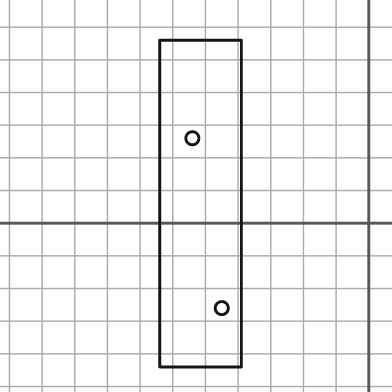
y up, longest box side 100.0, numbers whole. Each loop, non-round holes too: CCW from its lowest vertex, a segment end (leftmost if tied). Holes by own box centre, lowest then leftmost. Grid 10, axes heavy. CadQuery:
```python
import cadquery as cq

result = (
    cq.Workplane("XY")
    .moveTo(-64.0, -44.0)
    .lineTo(-39.0, -44.0)
    .lineTo(-39.0, 56.0)
    .lineTo(-64.0, 56.0)
    .close()
    .moveTo(-45.0, -26.0)
    .circle(2.0)
    .moveTo(-54.0, 26.0)
    .circle(2.0)
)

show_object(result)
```